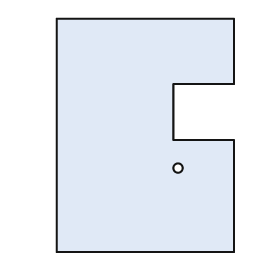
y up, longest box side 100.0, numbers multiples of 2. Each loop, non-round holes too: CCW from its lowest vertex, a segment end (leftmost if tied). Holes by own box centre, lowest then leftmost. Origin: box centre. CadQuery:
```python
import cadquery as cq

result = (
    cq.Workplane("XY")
    .moveTo(-38.0, -50.0)
    .lineTo(38.0, -50.0)
    .lineTo(38.0, -2.0)
    .lineTo(12.0, -2.0)
    .lineTo(12.0, 22.0)
    .lineTo(38.0, 22.0)
    .lineTo(38.0, 50.0)
    .lineTo(-38.0, 50.0)
    .close()
    .moveTo(14.0, -14.0)
    .circle(2.0)
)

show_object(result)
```